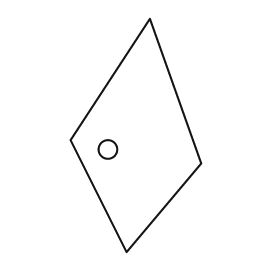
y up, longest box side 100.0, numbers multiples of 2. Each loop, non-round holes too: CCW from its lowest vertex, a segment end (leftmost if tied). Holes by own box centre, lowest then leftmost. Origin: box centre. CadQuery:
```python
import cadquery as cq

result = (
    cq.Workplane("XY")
    .moveTo(-4.0, -50.0)
    .lineTo(28.0, -12.0)
    .lineTo(6.0, 50.0)
    .lineTo(-28.0, -2.0)
    .close()
    .moveTo(-12.0, -6.0)
    .circle(4.0)
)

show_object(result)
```